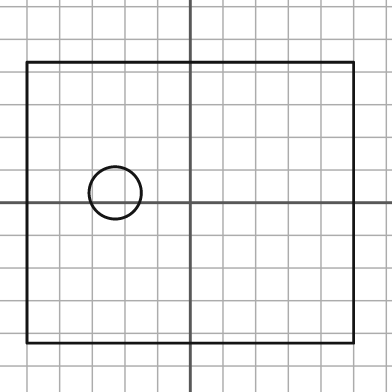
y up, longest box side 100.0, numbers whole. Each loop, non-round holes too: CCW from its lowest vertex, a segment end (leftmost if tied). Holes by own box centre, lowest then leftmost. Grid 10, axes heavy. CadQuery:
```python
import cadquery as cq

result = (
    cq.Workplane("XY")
    .moveTo(-50.0, -43.0)
    .lineTo(50.0, -43.0)
    .lineTo(50.0, 43.0)
    .lineTo(-50.0, 43.0)
    .close()
    .moveTo(-23.0, 3.0)
    .circle(8.0)
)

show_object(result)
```